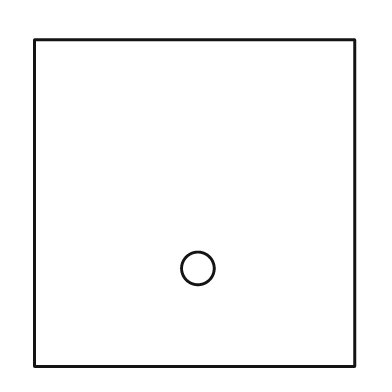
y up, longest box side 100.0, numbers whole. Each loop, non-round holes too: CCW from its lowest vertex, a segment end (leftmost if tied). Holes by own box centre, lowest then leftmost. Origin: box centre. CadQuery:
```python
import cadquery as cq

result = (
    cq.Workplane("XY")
    .moveTo(-49.0, -50.0)
    .lineTo(49.0, -50.0)
    .lineTo(49.0, 50.0)
    .lineTo(-49.0, 50.0)
    .close()
    .moveTo(1.0, -20.0)
    .circle(5.0)
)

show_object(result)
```